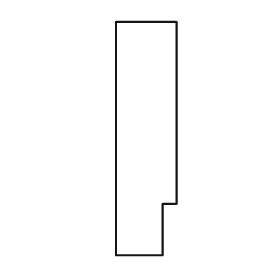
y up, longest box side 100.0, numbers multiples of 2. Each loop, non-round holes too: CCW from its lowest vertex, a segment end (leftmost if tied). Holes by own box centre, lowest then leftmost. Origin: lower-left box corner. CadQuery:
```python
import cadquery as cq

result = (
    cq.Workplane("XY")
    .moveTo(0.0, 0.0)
    .lineTo(20.0, 0.0)
    .lineTo(20.0, 22.0)
    .lineTo(26.0, 22.0)
    .lineTo(26.0, 100.0)
    .lineTo(0.0, 100.0)
    .close()
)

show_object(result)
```